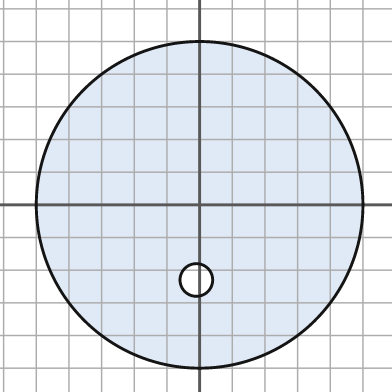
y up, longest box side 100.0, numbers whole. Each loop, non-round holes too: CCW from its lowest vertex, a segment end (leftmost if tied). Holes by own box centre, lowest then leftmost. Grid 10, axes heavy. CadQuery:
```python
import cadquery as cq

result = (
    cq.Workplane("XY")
    .moveTo(0.0, 0.0)
    .circle(50.0)
    .moveTo(-1.0, -23.0)
    .circle(5.0)
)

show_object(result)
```